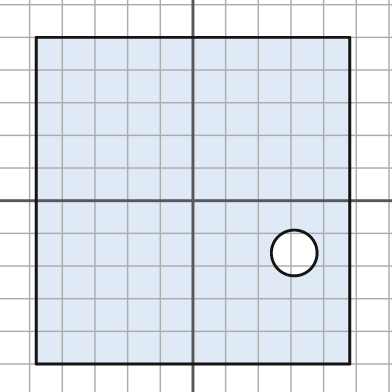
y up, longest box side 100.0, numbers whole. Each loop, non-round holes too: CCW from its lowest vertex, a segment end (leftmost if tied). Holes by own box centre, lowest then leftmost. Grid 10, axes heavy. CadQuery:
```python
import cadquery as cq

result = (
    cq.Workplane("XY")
    .moveTo(-48.0, -50.0)
    .lineTo(48.0, -50.0)
    .lineTo(48.0, 50.0)
    .lineTo(-48.0, 50.0)
    .close()
    .moveTo(31.0, -16.0)
    .circle(7.0)
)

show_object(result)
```